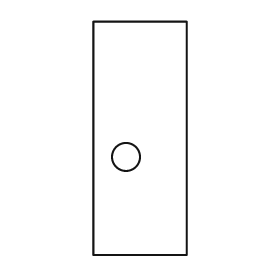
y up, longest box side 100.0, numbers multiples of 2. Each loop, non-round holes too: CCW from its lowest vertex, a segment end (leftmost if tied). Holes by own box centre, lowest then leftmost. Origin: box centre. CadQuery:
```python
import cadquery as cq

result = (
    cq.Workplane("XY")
    .moveTo(-20.0, -50.0)
    .lineTo(20.0, -50.0)
    .lineTo(20.0, 50.0)
    .lineTo(-20.0, 50.0)
    .close()
    .moveTo(-6.0, -8.0)
    .circle(6.0)
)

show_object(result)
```